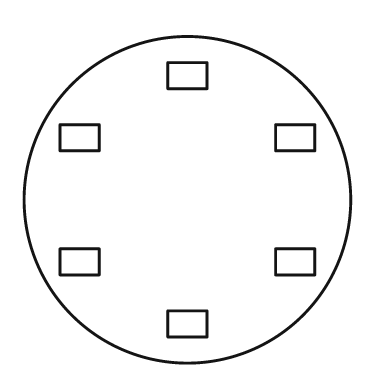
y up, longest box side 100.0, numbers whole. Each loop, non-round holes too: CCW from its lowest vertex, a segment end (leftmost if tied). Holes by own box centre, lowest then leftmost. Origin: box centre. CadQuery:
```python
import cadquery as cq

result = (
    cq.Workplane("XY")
    .moveTo(0.0, 0.0)
    .circle(50.0)
    .moveTo(-6.0, -42.0)
    .lineTo(6.0, -42.0)
    .lineTo(6.0, -34.0)
    .lineTo(-6.0, -34.0)
    .close()
    .moveTo(-39.0, -23.0)
    .lineTo(-27.0, -23.0)
    .lineTo(-27.0, -15.0)
    .lineTo(-39.0, -15.0)
    .close()
    .moveTo(27.0, -23.0)
    .lineTo(39.0, -23.0)
    .lineTo(39.0, -15.0)
    .lineTo(27.0, -15.0)
    .close()
    .moveTo(-39.0, 15.0)
    .lineTo(-27.0, 15.0)
    .lineTo(-27.0, 23.0)
    .lineTo(-39.0, 23.0)
    .close()
    .moveTo(27.0, 15.0)
    .lineTo(39.0, 15.0)
    .lineTo(39.0, 23.0)
    .lineTo(27.0, 23.0)
    .close()
    .moveTo(-6.0, 34.0)
    .lineTo(6.0, 34.0)
    .lineTo(6.0, 42.0)
    .lineTo(-6.0, 42.0)
    .close()
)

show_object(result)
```